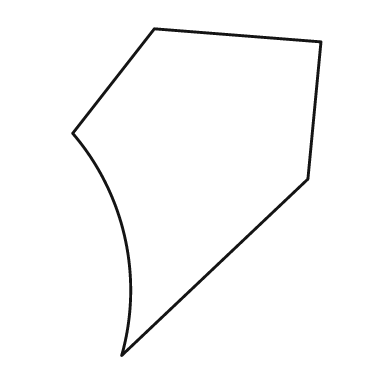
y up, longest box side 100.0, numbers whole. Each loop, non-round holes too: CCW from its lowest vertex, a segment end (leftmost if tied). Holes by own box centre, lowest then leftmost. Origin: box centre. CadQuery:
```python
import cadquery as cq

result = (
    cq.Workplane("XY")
    .moveTo(-23.0, -50.0)
    .lineTo(34.0, 4.0)
    .lineTo(38.0, 46.0)
    .lineTo(-13.0, 50.0)
    .lineTo(-38.0, 18.0)
    .threePointArc((-22.0, -14.0), (-23.0, -50.0))
    .close()
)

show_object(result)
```